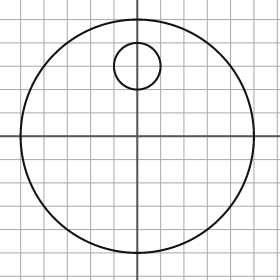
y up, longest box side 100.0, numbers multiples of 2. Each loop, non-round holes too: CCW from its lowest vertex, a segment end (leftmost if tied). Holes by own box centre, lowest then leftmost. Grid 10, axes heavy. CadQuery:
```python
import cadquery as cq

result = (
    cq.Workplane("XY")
    .moveTo(0.0, 0.0)
    .circle(50.0)
    .moveTo(0.0, 30.0)
    .circle(10.0)
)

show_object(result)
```